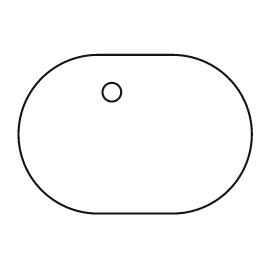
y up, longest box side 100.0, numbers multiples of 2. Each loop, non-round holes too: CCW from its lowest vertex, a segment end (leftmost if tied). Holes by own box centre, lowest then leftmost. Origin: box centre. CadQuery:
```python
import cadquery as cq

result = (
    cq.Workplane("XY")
    .moveTo(-16.0, -34.0)
    .lineTo(16.0, -34.0)
    .threePointArc((50.0, 0.0), (16.0, 34.0))
    .lineTo(-16.0, 34.0)
    .threePointArc((-50.0, 0.0), (-16.0, -34.0))
    .close()
    .moveTo(-10.0, 18.0)
    .circle(4.0)
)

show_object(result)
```